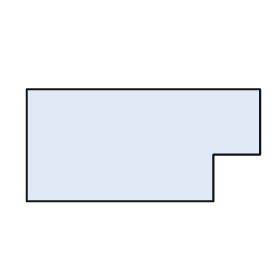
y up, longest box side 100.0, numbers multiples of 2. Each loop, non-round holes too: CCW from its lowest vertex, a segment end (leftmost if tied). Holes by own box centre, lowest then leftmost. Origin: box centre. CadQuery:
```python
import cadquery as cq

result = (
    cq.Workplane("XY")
    .moveTo(-50.0, -24.0)
    .lineTo(30.0, -24.0)
    .lineTo(30.0, -4.0)
    .lineTo(50.0, -4.0)
    .lineTo(50.0, 24.0)
    .lineTo(-50.0, 24.0)
    .close()
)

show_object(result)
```